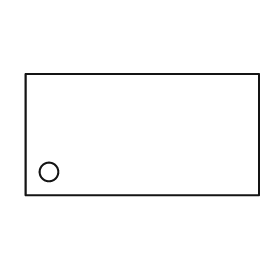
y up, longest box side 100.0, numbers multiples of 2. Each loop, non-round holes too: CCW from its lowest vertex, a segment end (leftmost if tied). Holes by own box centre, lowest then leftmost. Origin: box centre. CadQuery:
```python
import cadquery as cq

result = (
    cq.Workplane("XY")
    .moveTo(-50.0, -26.0)
    .lineTo(50.0, -26.0)
    .lineTo(50.0, 26.0)
    .lineTo(-50.0, 26.0)
    .close()
    .moveTo(-40.0, -16.0)
    .circle(4.0)
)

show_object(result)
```